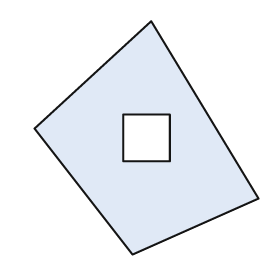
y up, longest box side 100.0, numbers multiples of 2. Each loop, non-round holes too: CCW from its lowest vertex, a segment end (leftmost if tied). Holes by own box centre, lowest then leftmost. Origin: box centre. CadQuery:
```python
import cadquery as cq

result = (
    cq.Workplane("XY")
    .moveTo(-6.0, -50.0)
    .lineTo(48.0, -26.0)
    .lineTo(2.0, 50.0)
    .lineTo(-48.0, 4.0)
    .close()
    .moveTo(-10.0, -10.0)
    .lineTo(10.0, -10.0)
    .lineTo(10.0, 10.0)
    .lineTo(-10.0, 10.0)
    .close()
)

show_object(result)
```